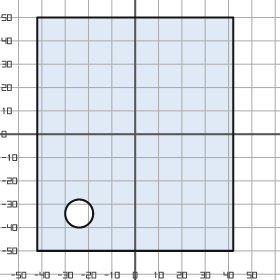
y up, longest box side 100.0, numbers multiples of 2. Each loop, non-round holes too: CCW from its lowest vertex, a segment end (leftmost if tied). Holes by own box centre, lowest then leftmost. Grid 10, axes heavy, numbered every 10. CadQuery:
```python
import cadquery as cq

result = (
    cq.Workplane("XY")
    .moveTo(-42.0, -50.0)
    .lineTo(42.0, -50.0)
    .lineTo(42.0, 50.0)
    .lineTo(-42.0, 50.0)
    .close()
    .moveTo(-24.0, -34.0)
    .circle(6.0)
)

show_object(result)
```